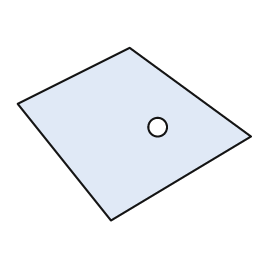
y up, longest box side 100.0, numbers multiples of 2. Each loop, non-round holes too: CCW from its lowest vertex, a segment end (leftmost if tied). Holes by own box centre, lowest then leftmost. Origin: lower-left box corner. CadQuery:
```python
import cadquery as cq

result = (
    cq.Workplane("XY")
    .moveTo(40.0, 0.0)
    .lineTo(100.0, 36.0)
    .lineTo(48.0, 74.0)
    .lineTo(0.0, 50.0)
    .close()
    .moveTo(60.0, 40.0)
    .circle(4.0)
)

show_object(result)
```